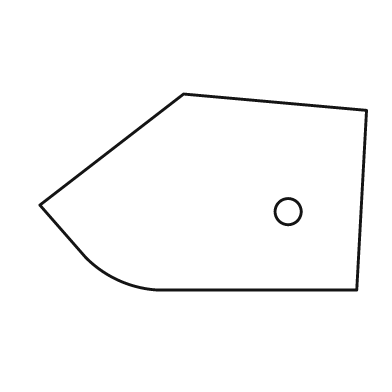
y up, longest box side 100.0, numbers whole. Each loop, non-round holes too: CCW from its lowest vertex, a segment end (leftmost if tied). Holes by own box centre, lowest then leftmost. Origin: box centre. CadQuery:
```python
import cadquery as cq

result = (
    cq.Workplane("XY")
    .moveTo(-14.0, -30.0)
    .lineTo(47.0, -30.0)
    .lineTo(50.0, 25.0)
    .lineTo(-6.0, 30.0)
    .lineTo(-50.0, -4.0)
    .lineTo(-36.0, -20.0)
    .threePointArc((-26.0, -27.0), (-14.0, -30.0))
    .close()
    .moveTo(26.0, -6.0)
    .circle(4.0)
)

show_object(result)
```